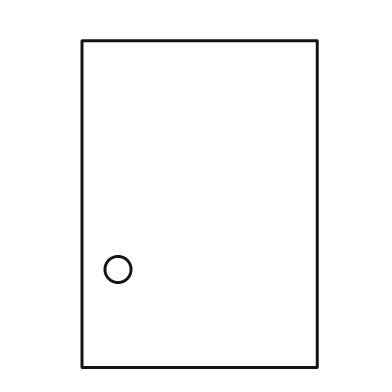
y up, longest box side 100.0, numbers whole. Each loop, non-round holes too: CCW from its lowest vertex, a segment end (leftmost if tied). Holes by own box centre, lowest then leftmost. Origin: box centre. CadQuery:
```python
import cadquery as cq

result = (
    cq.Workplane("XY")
    .moveTo(-36.0, -50.0)
    .lineTo(36.0, -50.0)
    .lineTo(36.0, 50.0)
    .lineTo(-36.0, 50.0)
    .close()
    .moveTo(-25.0, -20.0)
    .circle(4.0)
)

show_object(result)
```